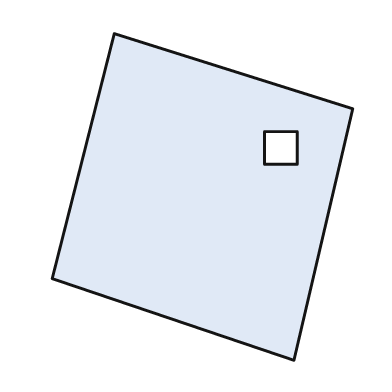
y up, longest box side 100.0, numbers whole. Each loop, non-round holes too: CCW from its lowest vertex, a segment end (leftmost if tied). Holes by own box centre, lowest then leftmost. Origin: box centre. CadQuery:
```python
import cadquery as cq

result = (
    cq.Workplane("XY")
    .moveTo(28.0, -50.0)
    .lineTo(46.0, 27.0)
    .lineTo(-27.0, 50.0)
    .lineTo(-46.0, -25.0)
    .close()
    .moveTo(19.0, 10.0)
    .lineTo(29.0, 10.0)
    .lineTo(29.0, 20.0)
    .lineTo(19.0, 20.0)
    .close()
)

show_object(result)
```